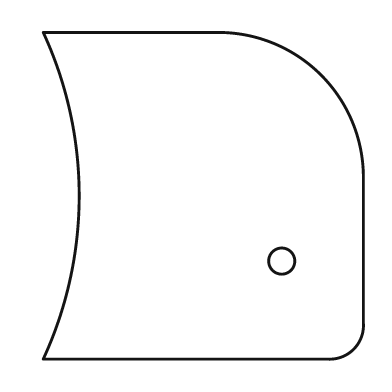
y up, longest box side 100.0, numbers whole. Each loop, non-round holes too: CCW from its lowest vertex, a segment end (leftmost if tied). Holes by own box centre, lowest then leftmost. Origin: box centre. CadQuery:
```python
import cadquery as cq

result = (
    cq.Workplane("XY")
    .moveTo(-49.0, -50.0)
    .lineTo(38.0, -50.0)
    .threePointArc((46.0, -47.0), (49.0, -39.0))
    .lineTo(49.0, 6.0)
    .threePointArc((36.0, 37.0), (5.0, 50.0))
    .lineTo(-49.0, 50.0)
    .threePointArc((-38.0, 0.0), (-49.0, -50.0))
    .close()
    .moveTo(24.0, -20.0)
    .circle(4.0)
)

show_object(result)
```